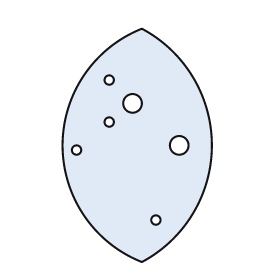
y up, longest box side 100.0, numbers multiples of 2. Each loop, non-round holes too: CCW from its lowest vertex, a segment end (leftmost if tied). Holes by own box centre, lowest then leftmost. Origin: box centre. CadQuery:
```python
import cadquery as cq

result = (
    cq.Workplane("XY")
    .moveTo(2.0, -50.0)
    .threePointArc((32.0, 0.0), (2.0, 50.0))
    .threePointArc((-32.0, 0.0), (2.0, -50.0))
    .close()
    .moveTo(8.0, -32.0)
    .circle(2.0)
    .moveTo(-26.0, -2.0)
    .circle(2.0)
    .moveTo(18.0, 0.0)
    .circle(4.0)
    .moveTo(-12.0, 10.0)
    .circle(2.0)
    .moveTo(-2.0, 18.0)
    .circle(4.0)
    .moveTo(-12.0, 28.0)
    .circle(2.0)
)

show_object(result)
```